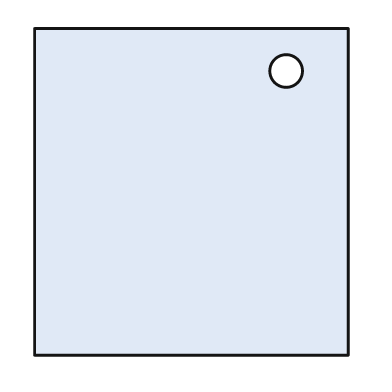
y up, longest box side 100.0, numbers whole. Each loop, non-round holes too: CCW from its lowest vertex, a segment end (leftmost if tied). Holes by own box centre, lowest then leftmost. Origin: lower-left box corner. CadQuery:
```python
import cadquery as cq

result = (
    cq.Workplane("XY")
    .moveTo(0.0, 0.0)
    .lineTo(96.0, 0.0)
    .lineTo(96.0, 100.0)
    .lineTo(0.0, 100.0)
    .close()
    .moveTo(77.0, 87.0)
    .circle(5.0)
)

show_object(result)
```